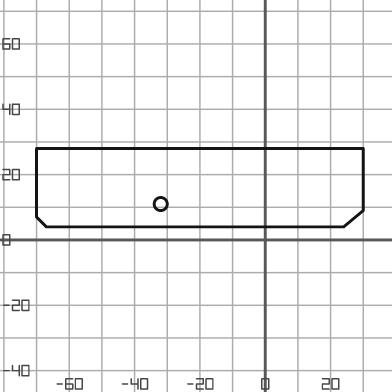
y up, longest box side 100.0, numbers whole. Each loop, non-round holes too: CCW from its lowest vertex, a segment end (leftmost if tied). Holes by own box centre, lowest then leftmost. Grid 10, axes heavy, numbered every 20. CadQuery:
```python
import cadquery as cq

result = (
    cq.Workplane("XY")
    .moveTo(-67.0, 4.0)
    .lineTo(24.0, 4.0)
    .lineTo(30.0, 9.0)
    .lineTo(30.0, 28.0)
    .lineTo(-70.0, 28.0)
    .lineTo(-70.0, 7.0)
    .close()
    .moveTo(-32.0, 11.0)
    .circle(2.0)
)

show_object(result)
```